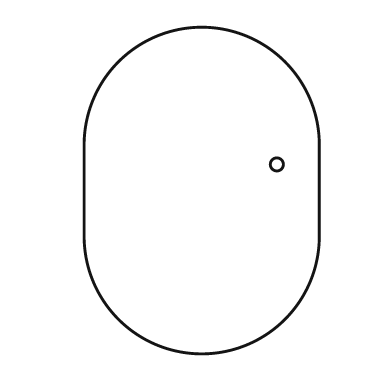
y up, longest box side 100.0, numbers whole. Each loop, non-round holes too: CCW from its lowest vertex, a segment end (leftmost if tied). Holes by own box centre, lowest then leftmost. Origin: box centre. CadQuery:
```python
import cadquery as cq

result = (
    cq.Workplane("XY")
    .moveTo(-36.0, -14.0)
    .threePointArc((0.0, -50.0), (36.0, -14.0))
    .lineTo(36.0, 14.0)
    .threePointArc((0.0, 50.0), (-36.0, 14.0))
    .close()
    .moveTo(23.0, 8.0)
    .circle(2.0)
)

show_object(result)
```